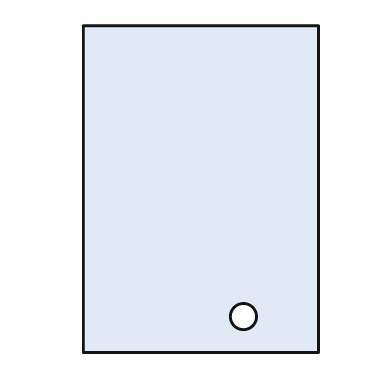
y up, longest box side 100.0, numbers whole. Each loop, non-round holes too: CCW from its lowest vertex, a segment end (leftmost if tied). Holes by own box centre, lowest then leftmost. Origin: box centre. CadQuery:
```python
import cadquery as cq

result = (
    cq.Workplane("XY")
    .moveTo(-36.0, -50.0)
    .lineTo(36.0, -50.0)
    .lineTo(36.0, 50.0)
    .lineTo(-36.0, 50.0)
    .close()
    .moveTo(13.0, -39.0)
    .circle(4.0)
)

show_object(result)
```